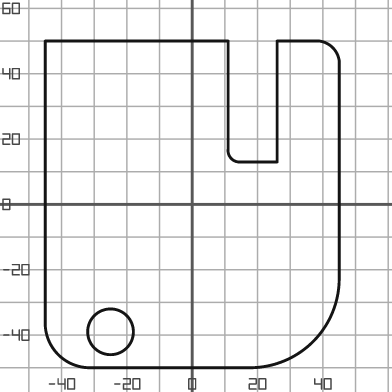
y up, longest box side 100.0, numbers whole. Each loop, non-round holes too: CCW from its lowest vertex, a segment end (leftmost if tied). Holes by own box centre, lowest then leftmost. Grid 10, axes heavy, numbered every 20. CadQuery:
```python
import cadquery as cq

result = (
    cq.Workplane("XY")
    .moveTo(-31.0, -50.0)
    .lineTo(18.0, -50.0)
    .threePointArc((37.0, -42.0), (45.0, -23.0))
    .lineTo(45.0, 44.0)
    .threePointArc((43.0, 48.0), (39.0, 50.0))
    .lineTo(26.0, 50.0)
    .lineTo(26.0, 13.0)
    .lineTo(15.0, 13.0)
    .threePointArc((12.0, 14.0), (11.0, 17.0))
    .lineTo(11.0, 50.0)
    .lineTo(-45.0, 50.0)
    .lineTo(-45.0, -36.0)
    .threePointArc((-41.0, -46.0), (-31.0, -50.0))
    .close()
    .moveTo(-25.0, -39.0)
    .circle(7.0)
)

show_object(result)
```